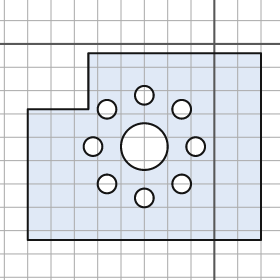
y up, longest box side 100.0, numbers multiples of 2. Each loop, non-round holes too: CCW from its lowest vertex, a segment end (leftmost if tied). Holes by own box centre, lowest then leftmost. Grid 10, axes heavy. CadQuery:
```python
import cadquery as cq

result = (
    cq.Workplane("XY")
    .moveTo(-80.0, -84.0)
    .lineTo(20.0, -84.0)
    .lineTo(20.0, -4.0)
    .lineTo(-54.0, -4.0)
    .lineTo(-54.0, -28.0)
    .lineTo(-80.0, -28.0)
    .close()
    .moveTo(-30.0, -66.0)
    .circle(4.0)
    .moveTo(-46.0, -60.0)
    .circle(4.0)
    .moveTo(-14.0, -60.0)
    .circle(4.0)
    .moveTo(-52.0, -44.0)
    .circle(4.0)
    .moveTo(-30.0, -44.0)
    .circle(10.0)
    .moveTo(-8.0, -44.0)
    .circle(4.0)
    .moveTo(-46.0, -28.0)
    .circle(4.0)
    .moveTo(-14.0, -28.0)
    .circle(4.0)
    .moveTo(-30.0, -22.0)
    .circle(4.0)
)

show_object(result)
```